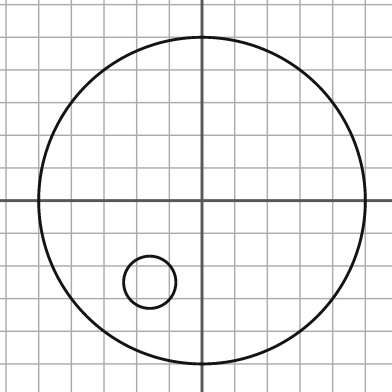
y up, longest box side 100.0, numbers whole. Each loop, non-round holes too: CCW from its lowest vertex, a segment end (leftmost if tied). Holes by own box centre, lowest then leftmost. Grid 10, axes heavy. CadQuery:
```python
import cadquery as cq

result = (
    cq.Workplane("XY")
    .moveTo(0.0, 0.0)
    .circle(50.0)
    .moveTo(-16.0, -25.0)
    .circle(8.0)
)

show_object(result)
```